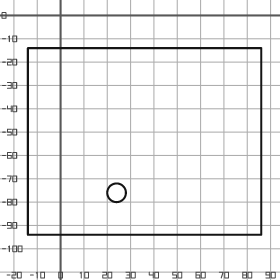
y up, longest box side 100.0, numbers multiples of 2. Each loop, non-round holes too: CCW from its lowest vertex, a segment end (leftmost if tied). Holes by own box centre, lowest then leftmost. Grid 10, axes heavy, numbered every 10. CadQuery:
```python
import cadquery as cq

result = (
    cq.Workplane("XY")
    .moveTo(-14.0, -94.0)
    .lineTo(86.0, -94.0)
    .lineTo(86.0, -14.0)
    .lineTo(-14.0, -14.0)
    .close()
    .moveTo(24.0, -76.0)
    .circle(4.0)
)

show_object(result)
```